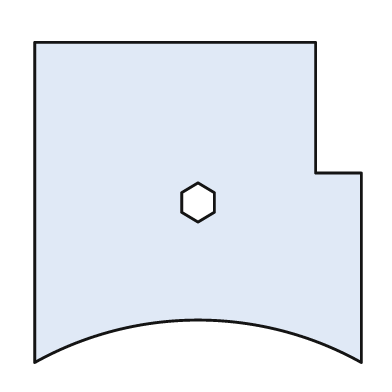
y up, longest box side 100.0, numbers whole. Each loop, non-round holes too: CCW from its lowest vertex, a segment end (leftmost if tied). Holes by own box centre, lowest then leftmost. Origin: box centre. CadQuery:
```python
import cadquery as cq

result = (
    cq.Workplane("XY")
    .moveTo(-50.0, -49.0)
    .threePointArc((0.0, -36.0), (50.0, -49.0))
    .lineTo(50.0, 9.0)
    .lineTo(36.0, 9.0)
    .lineTo(36.0, 49.0)
    .lineTo(-50.0, 49.0)
    .close()
    .moveTo(0.0, -6.0)
    .lineTo(5.0, -3.0)
    .lineTo(5.0, 3.0)
    .lineTo(0.0, 6.0)
    .lineTo(-5.0, 3.0)
    .lineTo(-5.0, -3.0)
    .close()
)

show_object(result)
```